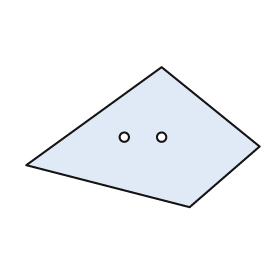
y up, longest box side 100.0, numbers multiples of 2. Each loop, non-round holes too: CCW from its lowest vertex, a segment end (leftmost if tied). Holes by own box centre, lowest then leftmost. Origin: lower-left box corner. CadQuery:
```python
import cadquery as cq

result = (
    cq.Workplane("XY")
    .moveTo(70.0, 0.0)
    .lineTo(100.0, 26.0)
    .lineTo(58.0, 60.0)
    .lineTo(0.0, 18.0)
    .close()
    .moveTo(42.0, 30.0)
    .circle(2.0)
    .moveTo(58.0, 30.0)
    .circle(2.0)
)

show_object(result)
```